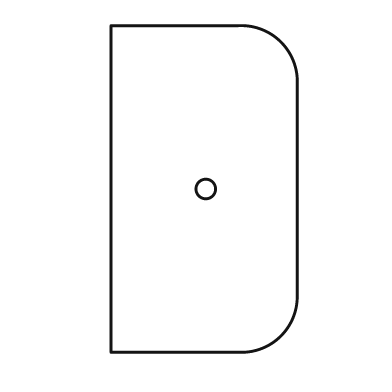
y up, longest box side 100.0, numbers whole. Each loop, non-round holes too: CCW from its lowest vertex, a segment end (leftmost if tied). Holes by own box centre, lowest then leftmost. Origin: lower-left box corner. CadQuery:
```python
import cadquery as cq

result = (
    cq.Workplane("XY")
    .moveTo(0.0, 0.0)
    .lineTo(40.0, 0.0)
    .threePointArc((52.0, 5.0), (57.0, 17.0))
    .lineTo(57.0, 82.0)
    .threePointArc((52.0, 95.0), (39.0, 100.0))
    .lineTo(0.0, 100.0)
    .close()
    .moveTo(29.0, 50.0)
    .circle(3.0)
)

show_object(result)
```